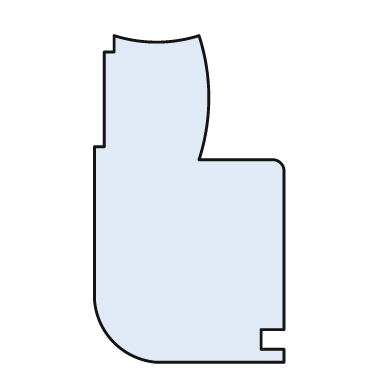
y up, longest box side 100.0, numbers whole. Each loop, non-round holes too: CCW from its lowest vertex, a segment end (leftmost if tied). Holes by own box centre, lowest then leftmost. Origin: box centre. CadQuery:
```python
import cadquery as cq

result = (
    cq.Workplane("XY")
    .moveTo(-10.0, -50.0)
    .lineTo(29.0, -50.0)
    .lineTo(29.0, -46.0)
    .lineTo(22.0, -46.0)
    .lineTo(22.0, -40.0)
    .lineTo(29.0, -40.0)
    .lineTo(29.0, 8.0)
    .threePointArc((28.0, 11.0), (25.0, 12.0))
    .lineTo(3.0, 12.0)
    .threePointArc((6.0, 31.0), (3.0, 50.0))
    .threePointArc((-10.0, 48.0), (-23.0, 50.0))
    .lineTo(-23.0, 45.0)
    .lineTo(-26.0, 45.0)
    .lineTo(-26.0, 16.0)
    .lineTo(-29.0, 16.0)
    .lineTo(-29.0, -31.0)
    .threePointArc((-23.0, -44.0), (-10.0, -50.0))
    .close()
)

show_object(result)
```